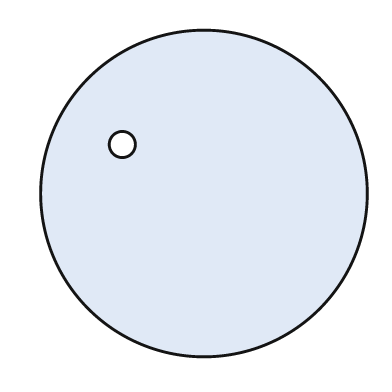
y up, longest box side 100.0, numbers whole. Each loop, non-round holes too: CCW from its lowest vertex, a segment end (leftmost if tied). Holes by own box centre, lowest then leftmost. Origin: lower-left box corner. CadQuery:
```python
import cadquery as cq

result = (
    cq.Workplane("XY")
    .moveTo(50.0, 50.0)
    .circle(50.0)
    .moveTo(25.0, 65.0)
    .circle(4.0)
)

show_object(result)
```